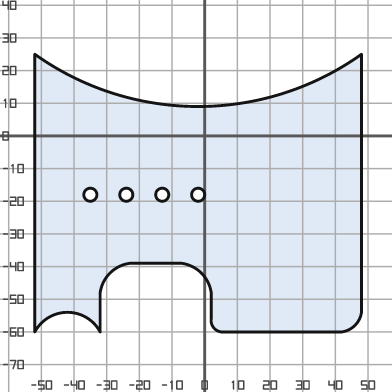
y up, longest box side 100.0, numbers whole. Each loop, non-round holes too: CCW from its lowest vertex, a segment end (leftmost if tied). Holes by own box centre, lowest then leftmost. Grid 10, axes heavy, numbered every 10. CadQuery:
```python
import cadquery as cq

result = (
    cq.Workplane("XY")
    .moveTo(-52.0, -60.0)
    .threePointArc((-42.0, -54.0), (-32.0, -60.0))
    .lineTo(-32.0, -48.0)
    .threePointArc((-29.0, -42.0), (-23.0, -39.0))
    .lineTo(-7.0, -39.0)
    .threePointArc((-1.0, -42.0), (2.0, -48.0))
    .lineTo(2.0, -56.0)
    .threePointArc((3.0, -59.0), (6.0, -60.0))
    .lineTo(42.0, -60.0)
    .threePointArc((46.0, -58.0), (48.0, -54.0))
    .lineTo(48.0, 25.0)
    .threePointArc((-2.0, 9.0), (-52.0, 25.0))
    .close()
    .moveTo(-35.0, -18.0)
    .circle(2.0)
    .moveTo(-24.0, -18.0)
    .circle(2.0)
    .moveTo(-13.0, -18.0)
    .circle(2.0)
    .moveTo(-2.0, -18.0)
    .circle(2.0)
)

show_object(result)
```